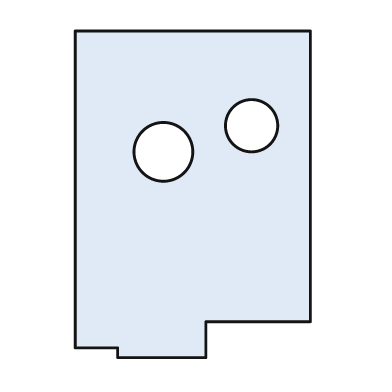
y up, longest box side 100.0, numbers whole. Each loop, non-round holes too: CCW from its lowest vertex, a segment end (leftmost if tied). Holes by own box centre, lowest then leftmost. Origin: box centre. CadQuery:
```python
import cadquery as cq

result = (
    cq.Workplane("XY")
    .moveTo(-23.0, -50.0)
    .lineTo(4.0, -50.0)
    .lineTo(4.0, -39.0)
    .lineTo(36.0, -39.0)
    .lineTo(36.0, 50.0)
    .lineTo(-36.0, 50.0)
    .lineTo(-36.0, -47.0)
    .lineTo(-23.0, -47.0)
    .close()
    .moveTo(-9.0, 13.0)
    .circle(9.0)
    .moveTo(18.0, 21.0)
    .circle(8.0)
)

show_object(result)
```